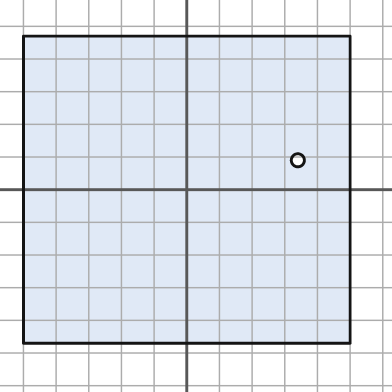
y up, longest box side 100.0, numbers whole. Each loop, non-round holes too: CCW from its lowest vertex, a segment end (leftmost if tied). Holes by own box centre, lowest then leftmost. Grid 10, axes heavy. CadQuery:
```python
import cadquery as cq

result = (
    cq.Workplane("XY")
    .moveTo(-50.0, -47.0)
    .lineTo(50.0, -47.0)
    .lineTo(50.0, 47.0)
    .lineTo(-50.0, 47.0)
    .close()
    .moveTo(34.0, 9.0)
    .circle(2.0)
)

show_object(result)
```